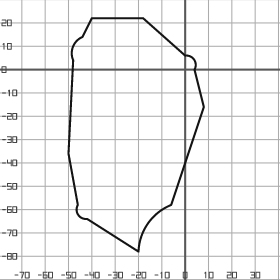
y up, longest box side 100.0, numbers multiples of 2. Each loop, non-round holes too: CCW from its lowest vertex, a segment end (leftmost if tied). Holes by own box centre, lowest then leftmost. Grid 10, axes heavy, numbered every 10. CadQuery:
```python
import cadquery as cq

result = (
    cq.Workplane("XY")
    .moveTo(-20.0, -78.0)
    .threePointArc((-16.0, -66.0), (-6.0, -58.0))
    .lineTo(8.0, -16.0)
    .lineTo(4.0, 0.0)
    .threePointArc((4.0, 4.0), (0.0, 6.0))
    .lineTo(-18.0, 22.0)
    .lineTo(-40.0, 22.0)
    .lineTo(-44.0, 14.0)
    .threePointArc((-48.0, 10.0), (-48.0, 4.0))
    .lineTo(-50.0, -36.0)
    .lineTo(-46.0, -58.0)
    .threePointArc((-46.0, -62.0), (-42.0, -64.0))
    .close()
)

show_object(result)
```